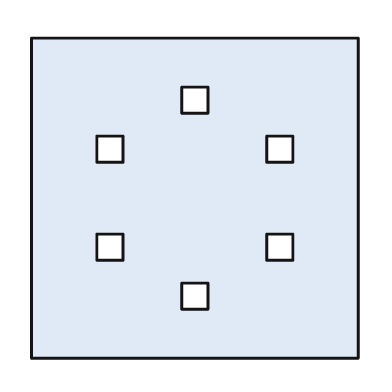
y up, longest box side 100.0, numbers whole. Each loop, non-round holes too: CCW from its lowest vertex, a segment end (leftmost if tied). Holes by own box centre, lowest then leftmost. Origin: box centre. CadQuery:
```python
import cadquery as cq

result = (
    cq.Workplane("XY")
    .moveTo(-50.0, -49.0)
    .lineTo(50.0, -49.0)
    .lineTo(50.0, 49.0)
    .lineTo(-50.0, 49.0)
    .close()
    .moveTo(-4.0, -34.0)
    .lineTo(4.0, -34.0)
    .lineTo(4.0, -26.0)
    .lineTo(-4.0, -26.0)
    .close()
    .moveTo(-30.0, -19.0)
    .lineTo(-22.0, -19.0)
    .lineTo(-22.0, -11.0)
    .lineTo(-30.0, -11.0)
    .close()
    .moveTo(22.0, -19.0)
    .lineTo(30.0, -19.0)
    .lineTo(30.0, -11.0)
    .lineTo(22.0, -11.0)
    .close()
    .moveTo(-30.0, 11.0)
    .lineTo(-22.0, 11.0)
    .lineTo(-22.0, 19.0)
    .lineTo(-30.0, 19.0)
    .close()
    .moveTo(22.0, 11.0)
    .lineTo(30.0, 11.0)
    .lineTo(30.0, 19.0)
    .lineTo(22.0, 19.0)
    .close()
    .moveTo(-4.0, 26.0)
    .lineTo(4.0, 26.0)
    .lineTo(4.0, 34.0)
    .lineTo(-4.0, 34.0)
    .close()
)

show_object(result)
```